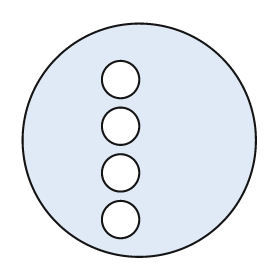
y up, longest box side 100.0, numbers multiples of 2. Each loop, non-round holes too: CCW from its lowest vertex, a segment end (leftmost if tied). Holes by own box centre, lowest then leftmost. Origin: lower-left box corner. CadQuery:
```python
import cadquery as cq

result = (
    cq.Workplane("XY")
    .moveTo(50.0, 50.0)
    .circle(50.0)
    .moveTo(42.0, 16.0)
    .circle(8.0)
    .moveTo(42.0, 36.0)
    .circle(8.0)
    .moveTo(42.0, 56.0)
    .circle(8.0)
    .moveTo(42.0, 76.0)
    .circle(8.0)
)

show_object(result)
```